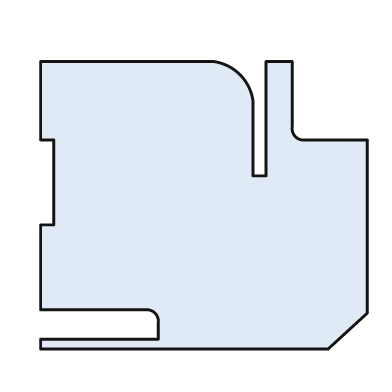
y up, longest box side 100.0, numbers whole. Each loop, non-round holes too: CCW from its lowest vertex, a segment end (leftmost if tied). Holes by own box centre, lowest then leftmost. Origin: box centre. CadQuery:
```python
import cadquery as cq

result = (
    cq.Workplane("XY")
    .moveTo(-50.0, -44.0)
    .lineTo(38.0, -44.0)
    .lineTo(50.0, -33.0)
    .lineTo(50.0, 20.0)
    .lineTo(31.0, 20.0)
    .threePointArc((28.0, 21.0), (27.0, 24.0))
    .lineTo(27.0, 44.0)
    .lineTo(19.0, 44.0)
    .lineTo(19.0, 9.0)
    .lineTo(15.0, 9.0)
    .lineTo(15.0, 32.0)
    .threePointArc((11.0, 40.0), (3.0, 44.0))
    .lineTo(-50.0, 44.0)
    .lineTo(-50.0, 20.0)
    .lineTo(-46.0, 20.0)
    .lineTo(-46.0, -6.0)
    .lineTo(-50.0, -6.0)
    .lineTo(-50.0, -32.0)
    .lineTo(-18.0, -32.0)
    .threePointArc((-15.0, -33.0), (-14.0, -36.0))
    .lineTo(-14.0, -41.0)
    .lineTo(-50.0, -41.0)
    .close()
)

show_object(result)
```